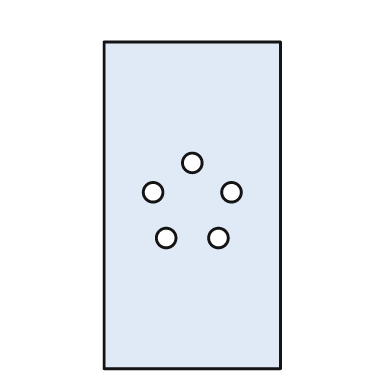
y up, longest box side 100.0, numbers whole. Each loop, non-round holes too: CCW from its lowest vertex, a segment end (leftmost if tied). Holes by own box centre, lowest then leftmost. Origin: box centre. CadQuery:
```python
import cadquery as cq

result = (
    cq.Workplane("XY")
    .moveTo(-27.0, -50.0)
    .lineTo(27.0, -50.0)
    .lineTo(27.0, 50.0)
    .lineTo(-27.0, 50.0)
    .close()
    .moveTo(-8.0, -10.0)
    .circle(3.0)
    .moveTo(8.0, -10.0)
    .circle(3.0)
    .moveTo(-12.0, 4.0)
    .circle(3.0)
    .moveTo(12.0, 4.0)
    .circle(3.0)
    .moveTo(0.0, 13.0)
    .circle(3.0)
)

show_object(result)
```